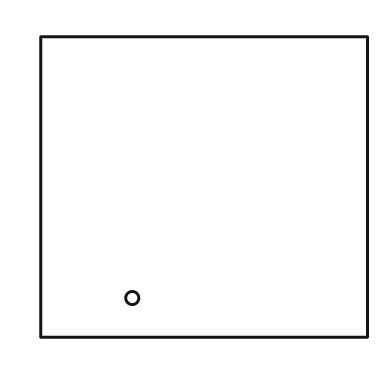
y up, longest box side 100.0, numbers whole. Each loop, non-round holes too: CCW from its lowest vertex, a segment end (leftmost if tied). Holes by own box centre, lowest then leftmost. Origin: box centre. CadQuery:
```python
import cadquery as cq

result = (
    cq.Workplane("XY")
    .moveTo(-50.0, -46.0)
    .lineTo(50.0, -46.0)
    .lineTo(50.0, 46.0)
    .lineTo(-50.0, 46.0)
    .close()
    .moveTo(-22.0, -34.0)
    .circle(2.0)
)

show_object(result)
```